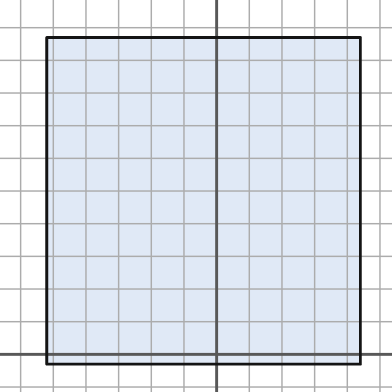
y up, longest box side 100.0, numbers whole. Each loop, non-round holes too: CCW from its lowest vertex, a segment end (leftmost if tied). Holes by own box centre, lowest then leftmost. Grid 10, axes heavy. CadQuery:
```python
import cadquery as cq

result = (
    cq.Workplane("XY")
    .moveTo(-52.0, -3.0)
    .lineTo(44.0, -3.0)
    .lineTo(44.0, 97.0)
    .lineTo(-52.0, 97.0)
    .close()
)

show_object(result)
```